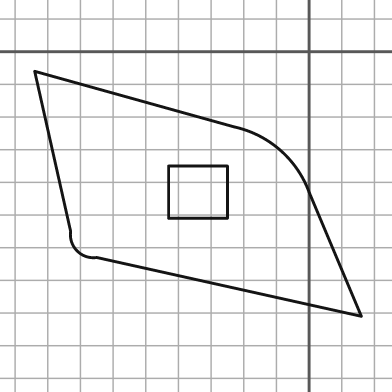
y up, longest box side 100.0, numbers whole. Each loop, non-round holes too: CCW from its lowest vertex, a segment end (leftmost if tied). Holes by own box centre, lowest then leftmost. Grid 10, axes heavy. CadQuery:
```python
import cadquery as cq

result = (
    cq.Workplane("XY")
    .moveTo(16.0, -81.0)
    .lineTo(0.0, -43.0)
    .threePointArc((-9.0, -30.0), (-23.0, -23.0))
    .lineTo(-84.0, -6.0)
    .lineTo(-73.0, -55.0)
    .threePointArc((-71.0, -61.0), (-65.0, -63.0))
    .close()
    .moveTo(-43.0, -51.0)
    .lineTo(-25.0, -51.0)
    .lineTo(-25.0, -35.0)
    .lineTo(-43.0, -35.0)
    .close()
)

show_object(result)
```